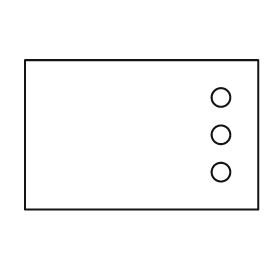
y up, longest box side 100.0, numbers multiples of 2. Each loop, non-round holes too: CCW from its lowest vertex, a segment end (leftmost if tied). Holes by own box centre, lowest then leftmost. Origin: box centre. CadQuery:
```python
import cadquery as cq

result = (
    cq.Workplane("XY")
    .moveTo(-50.0, -32.0)
    .lineTo(50.0, -32.0)
    .lineTo(50.0, 32.0)
    .lineTo(-50.0, 32.0)
    .close()
    .moveTo(34.0, -16.0)
    .circle(4.0)
    .moveTo(34.0, 0.0)
    .circle(4.0)
    .moveTo(34.0, 16.0)
    .circle(4.0)
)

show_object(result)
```